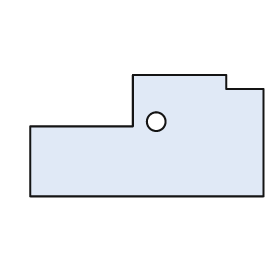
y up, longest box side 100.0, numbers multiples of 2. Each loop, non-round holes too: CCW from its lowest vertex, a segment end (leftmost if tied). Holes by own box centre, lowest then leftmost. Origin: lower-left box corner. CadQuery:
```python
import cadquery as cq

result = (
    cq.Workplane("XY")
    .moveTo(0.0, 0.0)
    .lineTo(100.0, 0.0)
    .lineTo(100.0, 46.0)
    .lineTo(84.0, 46.0)
    .lineTo(84.0, 52.0)
    .lineTo(44.0, 52.0)
    .lineTo(44.0, 30.0)
    .lineTo(0.0, 30.0)
    .close()
    .moveTo(54.0, 32.0)
    .circle(4.0)
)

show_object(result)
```